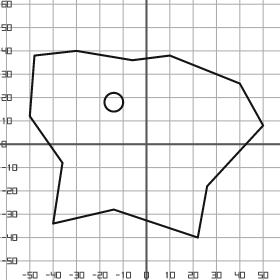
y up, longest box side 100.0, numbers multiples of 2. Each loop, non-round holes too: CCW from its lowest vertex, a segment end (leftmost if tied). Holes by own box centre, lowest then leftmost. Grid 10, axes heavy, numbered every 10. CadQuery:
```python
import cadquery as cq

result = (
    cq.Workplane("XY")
    .moveTo(22.0, -40.0)
    .lineTo(26.0, -18.0)
    .lineTo(50.0, 8.0)
    .lineTo(40.0, 26.0)
    .lineTo(10.0, 38.0)
    .lineTo(-6.0, 36.0)
    .lineTo(-30.0, 40.0)
    .lineTo(-48.0, 38.0)
    .lineTo(-50.0, 12.0)
    .lineTo(-36.0, -8.0)
    .lineTo(-40.0, -34.0)
    .lineTo(-14.0, -28.0)
    .close()
    .moveTo(-14.0, 18.0)
    .circle(4.0)
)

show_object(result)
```